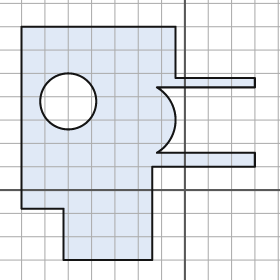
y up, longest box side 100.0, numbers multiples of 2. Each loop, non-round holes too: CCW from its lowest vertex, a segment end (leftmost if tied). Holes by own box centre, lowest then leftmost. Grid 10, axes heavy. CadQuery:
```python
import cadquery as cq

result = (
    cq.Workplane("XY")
    .moveTo(-52.0, -30.0)
    .lineTo(-14.0, -30.0)
    .lineTo(-14.0, 10.0)
    .lineTo(30.0, 10.0)
    .lineTo(30.0, 16.0)
    .lineTo(-12.0, 16.0)
    .threePointArc((-4.0, 30.0), (-12.0, 44.0))
    .lineTo(30.0, 44.0)
    .lineTo(30.0, 48.0)
    .lineTo(-4.0, 48.0)
    .lineTo(-4.0, 70.0)
    .lineTo(-70.0, 70.0)
    .lineTo(-70.0, -8.0)
    .lineTo(-52.0, -8.0)
    .close()
    .moveTo(-50.0, 38.0)
    .circle(12.0)
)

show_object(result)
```